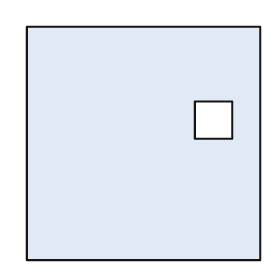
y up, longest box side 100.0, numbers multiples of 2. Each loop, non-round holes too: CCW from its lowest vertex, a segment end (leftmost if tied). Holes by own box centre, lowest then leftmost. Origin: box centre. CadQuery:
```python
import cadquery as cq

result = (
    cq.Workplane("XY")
    .moveTo(-50.0, -50.0)
    .lineTo(50.0, -50.0)
    .lineTo(50.0, 50.0)
    .lineTo(-50.0, 50.0)
    .close()
    .moveTo(22.0, 2.0)
    .lineTo(38.0, 2.0)
    .lineTo(38.0, 18.0)
    .lineTo(22.0, 18.0)
    .close()
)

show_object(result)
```